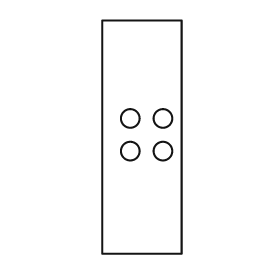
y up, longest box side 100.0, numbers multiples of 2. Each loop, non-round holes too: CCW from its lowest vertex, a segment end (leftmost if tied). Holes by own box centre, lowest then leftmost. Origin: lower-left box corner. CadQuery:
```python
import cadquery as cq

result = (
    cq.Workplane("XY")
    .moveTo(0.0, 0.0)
    .lineTo(34.0, 0.0)
    .lineTo(34.0, 100.0)
    .lineTo(0.0, 100.0)
    .close()
    .moveTo(12.0, 44.0)
    .circle(4.0)
    .moveTo(26.0, 44.0)
    .circle(4.0)
    .moveTo(12.0, 58.0)
    .circle(4.0)
    .moveTo(26.0, 58.0)
    .circle(4.0)
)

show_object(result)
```